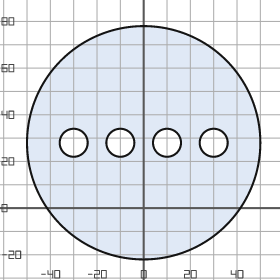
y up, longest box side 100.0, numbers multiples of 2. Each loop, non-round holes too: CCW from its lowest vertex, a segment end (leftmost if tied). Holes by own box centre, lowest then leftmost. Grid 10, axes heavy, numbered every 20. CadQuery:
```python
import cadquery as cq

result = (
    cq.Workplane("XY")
    .moveTo(0.0, 28.0)
    .circle(50.0)
    .moveTo(-30.0, 28.0)
    .circle(6.0)
    .moveTo(-10.0, 28.0)
    .circle(6.0)
    .moveTo(10.0, 28.0)
    .circle(6.0)
    .moveTo(30.0, 28.0)
    .circle(6.0)
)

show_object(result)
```